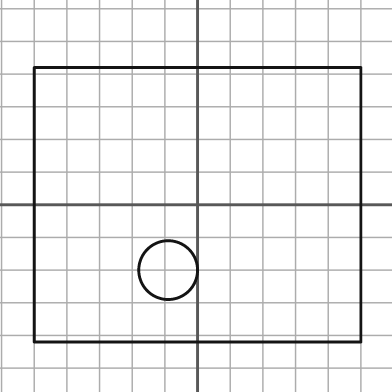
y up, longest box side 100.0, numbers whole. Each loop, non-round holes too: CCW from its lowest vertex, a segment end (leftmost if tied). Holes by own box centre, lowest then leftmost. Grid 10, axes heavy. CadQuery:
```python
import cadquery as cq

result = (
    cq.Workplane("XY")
    .moveTo(-50.0, -42.0)
    .lineTo(50.0, -42.0)
    .lineTo(50.0, 42.0)
    .lineTo(-50.0, 42.0)
    .close()
    .moveTo(-9.0, -20.0)
    .circle(9.0)
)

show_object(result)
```